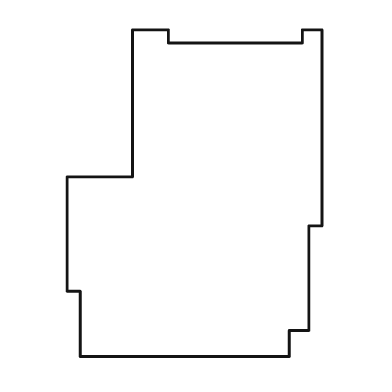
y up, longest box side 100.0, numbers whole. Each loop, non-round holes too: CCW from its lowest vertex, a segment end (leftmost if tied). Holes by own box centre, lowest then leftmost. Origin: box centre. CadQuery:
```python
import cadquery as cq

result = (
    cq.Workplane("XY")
    .moveTo(-35.0, -50.0)
    .lineTo(29.0, -50.0)
    .lineTo(29.0, -42.0)
    .lineTo(35.0, -42.0)
    .lineTo(35.0, -10.0)
    .lineTo(39.0, -10.0)
    .lineTo(39.0, 50.0)
    .lineTo(33.0, 50.0)
    .lineTo(33.0, 46.0)
    .lineTo(-8.0, 46.0)
    .lineTo(-8.0, 50.0)
    .lineTo(-19.0, 50.0)
    .lineTo(-19.0, 5.0)
    .lineTo(-39.0, 5.0)
    .lineTo(-39.0, -30.0)
    .lineTo(-35.0, -30.0)
    .close()
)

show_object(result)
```